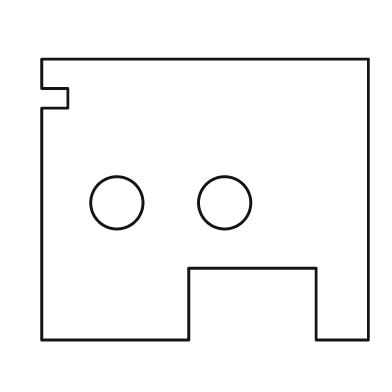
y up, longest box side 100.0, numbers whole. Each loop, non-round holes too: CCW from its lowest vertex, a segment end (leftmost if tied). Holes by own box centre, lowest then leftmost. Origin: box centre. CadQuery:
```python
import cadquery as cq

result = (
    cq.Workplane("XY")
    .moveTo(-50.0, -43.0)
    .lineTo(-5.0, -43.0)
    .lineTo(-5.0, -21.0)
    .lineTo(34.0, -21.0)
    .lineTo(34.0, -43.0)
    .lineTo(50.0, -43.0)
    .lineTo(50.0, 43.0)
    .lineTo(-50.0, 43.0)
    .lineTo(-50.0, 34.0)
    .lineTo(-42.0, 34.0)
    .lineTo(-42.0, 28.0)
    .lineTo(-50.0, 28.0)
    .close()
    .moveTo(-27.0, -1.0)
    .circle(8.0)
    .moveTo(6.0, -1.0)
    .circle(8.0)
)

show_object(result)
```